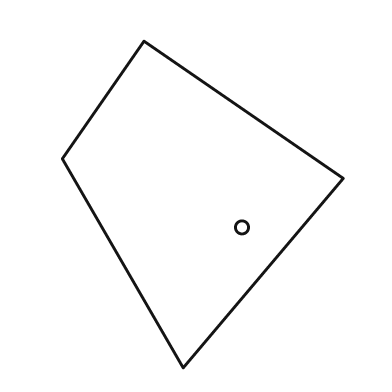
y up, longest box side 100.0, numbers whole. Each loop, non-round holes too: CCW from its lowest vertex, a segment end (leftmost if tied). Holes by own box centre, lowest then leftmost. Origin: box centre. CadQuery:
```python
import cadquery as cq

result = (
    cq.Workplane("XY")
    .moveTo(-6.0, -50.0)
    .lineTo(43.0, 8.0)
    .lineTo(-18.0, 50.0)
    .lineTo(-43.0, 14.0)
    .close()
    .moveTo(12.0, -7.0)
    .circle(2.0)
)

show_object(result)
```